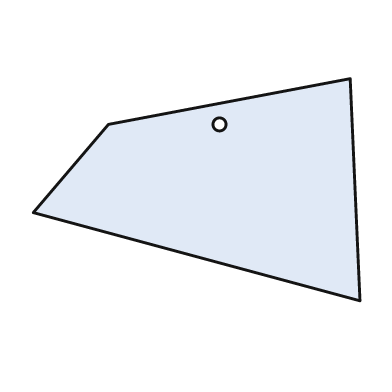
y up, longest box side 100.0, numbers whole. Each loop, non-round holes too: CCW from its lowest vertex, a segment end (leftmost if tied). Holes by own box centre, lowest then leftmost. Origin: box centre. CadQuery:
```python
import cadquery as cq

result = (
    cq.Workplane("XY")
    .moveTo(50.0, -34.0)
    .lineTo(47.0, 34.0)
    .lineTo(-27.0, 20.0)
    .lineTo(-50.0, -7.0)
    .close()
    .moveTo(7.0, 20.0)
    .circle(2.0)
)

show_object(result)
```